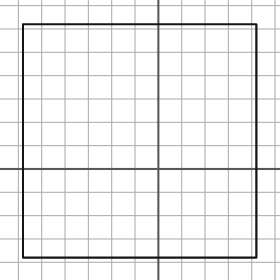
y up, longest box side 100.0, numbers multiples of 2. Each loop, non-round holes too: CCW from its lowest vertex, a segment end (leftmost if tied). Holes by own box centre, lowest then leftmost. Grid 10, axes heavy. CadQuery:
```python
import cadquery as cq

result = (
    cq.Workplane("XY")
    .moveTo(-58.0, -38.0)
    .lineTo(42.0, -38.0)
    .lineTo(42.0, 62.0)
    .lineTo(-58.0, 62.0)
    .close()
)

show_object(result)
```